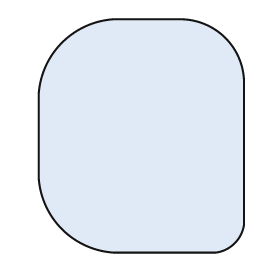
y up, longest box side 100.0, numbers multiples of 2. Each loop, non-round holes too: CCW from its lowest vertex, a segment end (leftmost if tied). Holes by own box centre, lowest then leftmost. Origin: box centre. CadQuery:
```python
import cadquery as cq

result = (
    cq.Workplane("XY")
    .moveTo(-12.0, -50.0)
    .lineTo(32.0, -50.0)
    .threePointArc((40.0, -46.0), (44.0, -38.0))
    .lineTo(44.0, 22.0)
    .threePointArc((36.0, 42.0), (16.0, 50.0))
    .lineTo(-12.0, 50.0)
    .threePointArc((-34.0, 40.0), (-44.0, 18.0))
    .lineTo(-44.0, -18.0)
    .threePointArc((-34.0, -40.0), (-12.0, -50.0))
    .close()
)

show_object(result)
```